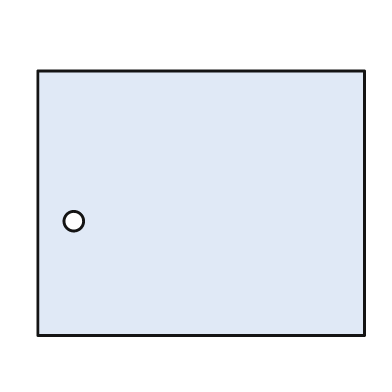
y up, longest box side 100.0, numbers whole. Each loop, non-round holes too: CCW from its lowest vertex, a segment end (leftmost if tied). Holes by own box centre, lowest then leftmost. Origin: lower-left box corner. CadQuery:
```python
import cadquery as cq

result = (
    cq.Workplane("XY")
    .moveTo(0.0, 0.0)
    .lineTo(100.0, 0.0)
    .lineTo(100.0, 81.0)
    .lineTo(0.0, 81.0)
    .close()
    .moveTo(11.0, 35.0)
    .circle(3.0)
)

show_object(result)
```